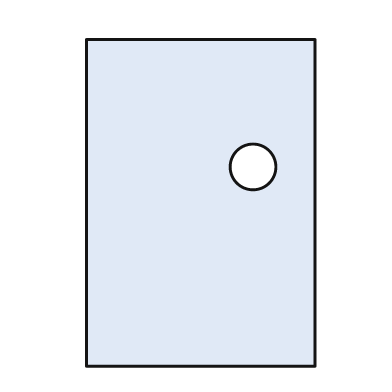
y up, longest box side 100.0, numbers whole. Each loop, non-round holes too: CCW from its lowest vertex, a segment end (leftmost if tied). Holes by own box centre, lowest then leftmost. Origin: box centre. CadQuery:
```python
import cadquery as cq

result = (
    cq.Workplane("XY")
    .moveTo(-35.0, -50.0)
    .lineTo(35.0, -50.0)
    .lineTo(35.0, 50.0)
    .lineTo(-35.0, 50.0)
    .close()
    .moveTo(16.0, 11.0)
    .circle(7.0)
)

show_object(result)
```